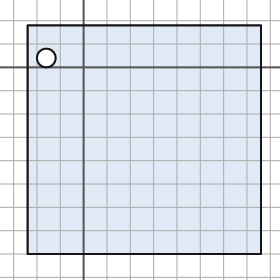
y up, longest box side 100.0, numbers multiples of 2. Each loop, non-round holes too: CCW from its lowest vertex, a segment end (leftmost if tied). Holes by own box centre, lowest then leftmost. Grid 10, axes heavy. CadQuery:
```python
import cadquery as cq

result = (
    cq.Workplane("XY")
    .moveTo(-24.0, -80.0)
    .lineTo(76.0, -80.0)
    .lineTo(76.0, 18.0)
    .lineTo(-24.0, 18.0)
    .close()
    .moveTo(-16.0, 4.0)
    .circle(4.0)
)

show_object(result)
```